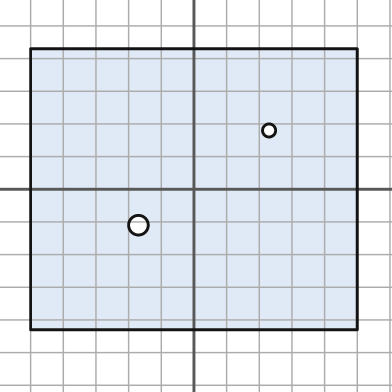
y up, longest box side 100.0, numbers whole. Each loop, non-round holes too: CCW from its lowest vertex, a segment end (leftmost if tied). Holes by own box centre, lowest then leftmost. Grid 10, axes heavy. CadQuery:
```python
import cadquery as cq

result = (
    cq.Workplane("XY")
    .moveTo(-50.0, -43.0)
    .lineTo(50.0, -43.0)
    .lineTo(50.0, 43.0)
    .lineTo(-50.0, 43.0)
    .close()
    .moveTo(-17.0, -11.0)
    .circle(3.0)
    .moveTo(23.0, 18.0)
    .circle(2.0)
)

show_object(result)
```